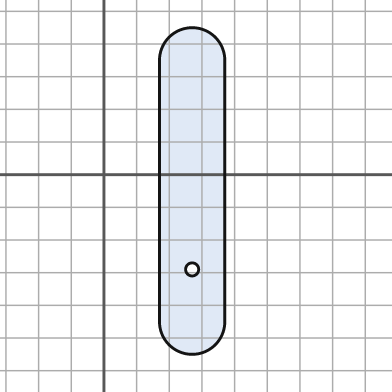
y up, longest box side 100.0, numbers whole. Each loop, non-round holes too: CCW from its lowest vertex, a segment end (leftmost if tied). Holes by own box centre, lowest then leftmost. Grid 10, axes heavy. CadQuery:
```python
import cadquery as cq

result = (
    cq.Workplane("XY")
    .moveTo(17.0, -45.0)
    .threePointArc((27.0, -55.0), (37.0, -45.0))
    .lineTo(37.0, 35.0)
    .threePointArc((27.0, 45.0), (17.0, 35.0))
    .close()
    .moveTo(27.0, -29.0)
    .circle(2.0)
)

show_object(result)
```